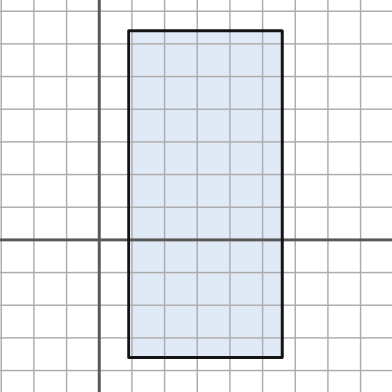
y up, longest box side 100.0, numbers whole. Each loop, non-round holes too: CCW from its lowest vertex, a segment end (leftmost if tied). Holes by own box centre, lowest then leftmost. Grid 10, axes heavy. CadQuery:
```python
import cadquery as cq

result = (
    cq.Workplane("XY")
    .moveTo(9.0, -36.0)
    .lineTo(56.0, -36.0)
    .lineTo(56.0, 64.0)
    .lineTo(9.0, 64.0)
    .close()
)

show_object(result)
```